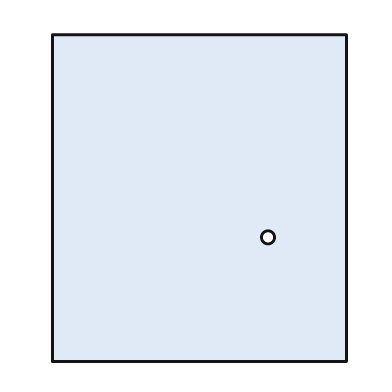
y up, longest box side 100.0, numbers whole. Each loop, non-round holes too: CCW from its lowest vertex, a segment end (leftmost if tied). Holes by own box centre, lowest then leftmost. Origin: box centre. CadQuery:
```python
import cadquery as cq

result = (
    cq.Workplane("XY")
    .moveTo(-45.0, -50.0)
    .lineTo(45.0, -50.0)
    .lineTo(45.0, 50.0)
    .lineTo(-45.0, 50.0)
    .close()
    .moveTo(21.0, -12.0)
    .circle(2.0)
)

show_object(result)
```